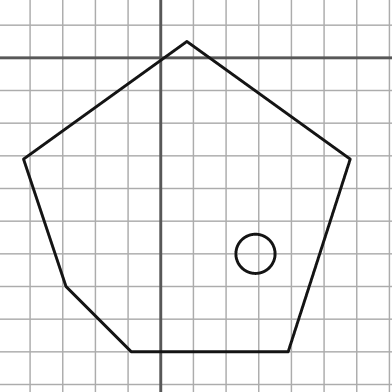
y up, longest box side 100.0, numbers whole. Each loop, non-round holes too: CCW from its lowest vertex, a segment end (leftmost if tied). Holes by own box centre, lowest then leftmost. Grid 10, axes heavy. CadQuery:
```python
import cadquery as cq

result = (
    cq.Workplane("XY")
    .moveTo(-9.0, -90.0)
    .lineTo(39.0, -90.0)
    .lineTo(58.0, -31.0)
    .lineTo(8.0, 5.0)
    .lineTo(-42.0, -31.0)
    .lineTo(-29.0, -70.0)
    .close()
    .moveTo(29.0, -60.0)
    .circle(6.0)
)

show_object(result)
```